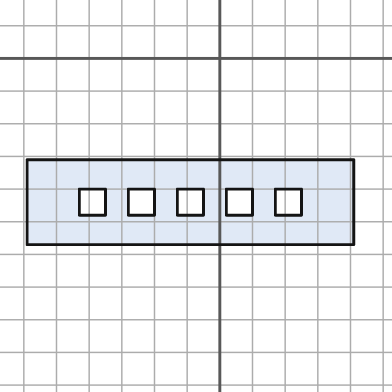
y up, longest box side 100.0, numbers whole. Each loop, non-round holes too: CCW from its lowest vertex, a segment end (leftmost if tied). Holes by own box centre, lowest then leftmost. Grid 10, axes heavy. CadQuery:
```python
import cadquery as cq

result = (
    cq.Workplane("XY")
    .moveTo(-59.0, -57.0)
    .lineTo(41.0, -57.0)
    .lineTo(41.0, -31.0)
    .lineTo(-59.0, -31.0)
    .close()
    .moveTo(-43.0, -48.0)
    .lineTo(-35.0, -48.0)
    .lineTo(-35.0, -40.0)
    .lineTo(-43.0, -40.0)
    .close()
    .moveTo(-28.0, -48.0)
    .lineTo(-20.0, -48.0)
    .lineTo(-20.0, -40.0)
    .lineTo(-28.0, -40.0)
    .close()
    .moveTo(-13.0, -48.0)
    .lineTo(-5.0, -48.0)
    .lineTo(-5.0, -40.0)
    .lineTo(-13.0, -40.0)
    .close()
    .moveTo(2.0, -48.0)
    .lineTo(10.0, -48.0)
    .lineTo(10.0, -40.0)
    .lineTo(2.0, -40.0)
    .close()
    .moveTo(17.0, -48.0)
    .lineTo(25.0, -48.0)
    .lineTo(25.0, -40.0)
    .lineTo(17.0, -40.0)
    .close()
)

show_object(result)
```